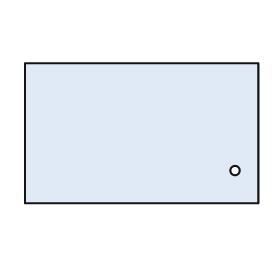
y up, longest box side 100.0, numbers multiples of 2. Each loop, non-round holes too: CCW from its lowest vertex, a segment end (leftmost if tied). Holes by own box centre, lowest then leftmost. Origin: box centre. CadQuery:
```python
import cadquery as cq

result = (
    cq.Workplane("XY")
    .moveTo(-50.0, -30.0)
    .lineTo(50.0, -30.0)
    .lineTo(50.0, 30.0)
    .lineTo(-50.0, 30.0)
    .close()
    .moveTo(40.0, -16.0)
    .circle(2.0)
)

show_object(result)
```